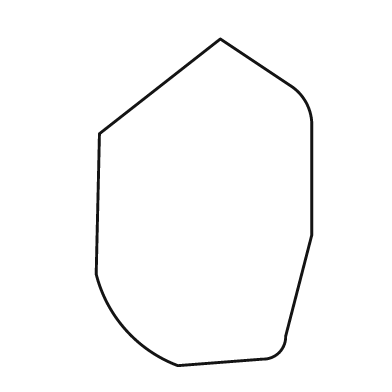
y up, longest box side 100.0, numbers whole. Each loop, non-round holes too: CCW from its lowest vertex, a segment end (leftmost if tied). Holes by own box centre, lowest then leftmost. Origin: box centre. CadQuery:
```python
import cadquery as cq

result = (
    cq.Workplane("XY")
    .moveTo(-8.0, -50.0)
    .lineTo(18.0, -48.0)
    .threePointArc((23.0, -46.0), (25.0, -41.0))
    .lineTo(33.0, -10.0)
    .lineTo(33.0, 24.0)
    .threePointArc((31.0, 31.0), (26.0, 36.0))
    .lineTo(5.0, 50.0)
    .lineTo(-32.0, 21.0)
    .lineTo(-33.0, -22.0)
    .threePointArc((-24.0, -39.0), (-8.0, -50.0))
    .close()
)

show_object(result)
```